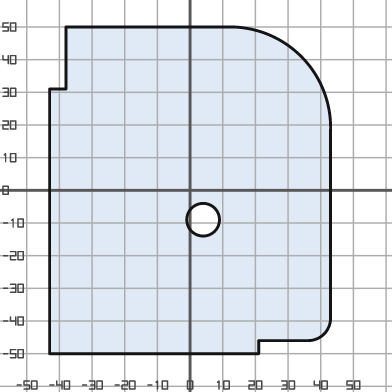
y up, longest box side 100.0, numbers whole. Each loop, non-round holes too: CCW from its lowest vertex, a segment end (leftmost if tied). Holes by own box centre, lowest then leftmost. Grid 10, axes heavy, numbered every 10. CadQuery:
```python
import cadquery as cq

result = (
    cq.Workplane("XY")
    .moveTo(-43.0, -50.0)
    .lineTo(21.0, -50.0)
    .lineTo(21.0, -46.0)
    .lineTo(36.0, -46.0)
    .threePointArc((41.0, -44.0), (43.0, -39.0))
    .lineTo(43.0, 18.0)
    .threePointArc((34.0, 41.0), (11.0, 50.0))
    .lineTo(-38.0, 50.0)
    .lineTo(-38.0, 31.0)
    .lineTo(-43.0, 31.0)
    .close()
    .moveTo(4.0, -9.0)
    .circle(5.0)
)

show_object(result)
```